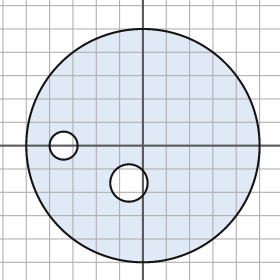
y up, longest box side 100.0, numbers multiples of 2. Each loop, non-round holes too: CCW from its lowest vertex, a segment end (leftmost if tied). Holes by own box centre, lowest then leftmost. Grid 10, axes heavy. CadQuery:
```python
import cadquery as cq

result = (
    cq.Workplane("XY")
    .moveTo(0.0, 0.0)
    .circle(50.0)
    .moveTo(-6.0, -16.0)
    .circle(8.0)
    .moveTo(-34.0, 0.0)
    .circle(6.0)
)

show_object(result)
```